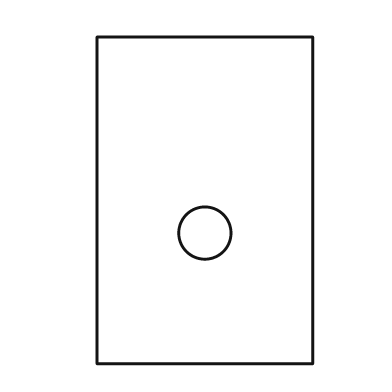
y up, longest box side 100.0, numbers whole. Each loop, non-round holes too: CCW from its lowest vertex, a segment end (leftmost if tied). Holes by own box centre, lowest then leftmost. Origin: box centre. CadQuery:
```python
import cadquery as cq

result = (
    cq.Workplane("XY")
    .moveTo(-33.0, -50.0)
    .lineTo(33.0, -50.0)
    .lineTo(33.0, 50.0)
    .lineTo(-33.0, 50.0)
    .close()
    .moveTo(0.0, -10.0)
    .circle(8.0)
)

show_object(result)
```